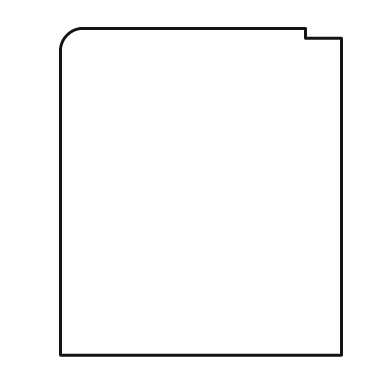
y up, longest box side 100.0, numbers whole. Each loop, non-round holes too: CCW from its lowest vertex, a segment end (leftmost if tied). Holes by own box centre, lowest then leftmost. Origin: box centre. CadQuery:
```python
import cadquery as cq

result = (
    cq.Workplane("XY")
    .moveTo(-43.0, -50.0)
    .lineTo(43.0, -50.0)
    .lineTo(43.0, 47.0)
    .lineTo(32.0, 47.0)
    .lineTo(32.0, 50.0)
    .lineTo(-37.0, 50.0)
    .threePointArc((-41.0, 48.0), (-43.0, 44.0))
    .close()
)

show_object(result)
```